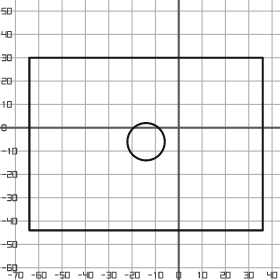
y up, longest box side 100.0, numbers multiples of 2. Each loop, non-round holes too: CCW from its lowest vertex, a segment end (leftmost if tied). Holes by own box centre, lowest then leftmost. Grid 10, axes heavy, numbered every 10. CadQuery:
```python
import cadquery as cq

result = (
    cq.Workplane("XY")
    .moveTo(-64.0, -44.0)
    .lineTo(36.0, -44.0)
    .lineTo(36.0, 30.0)
    .lineTo(-64.0, 30.0)
    .close()
    .moveTo(-14.0, -6.0)
    .circle(8.0)
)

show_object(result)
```